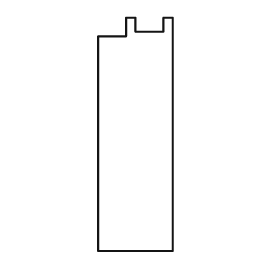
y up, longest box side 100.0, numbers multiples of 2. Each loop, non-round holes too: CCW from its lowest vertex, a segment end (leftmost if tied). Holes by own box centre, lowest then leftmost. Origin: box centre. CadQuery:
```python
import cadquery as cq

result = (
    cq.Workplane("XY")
    .moveTo(-16.0, -50.0)
    .lineTo(16.0, -50.0)
    .lineTo(16.0, 50.0)
    .lineTo(12.0, 50.0)
    .lineTo(12.0, 44.0)
    .lineTo(0.0, 44.0)
    .lineTo(0.0, 50.0)
    .lineTo(-4.0, 50.0)
    .lineTo(-4.0, 42.0)
    .lineTo(-16.0, 42.0)
    .close()
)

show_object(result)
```